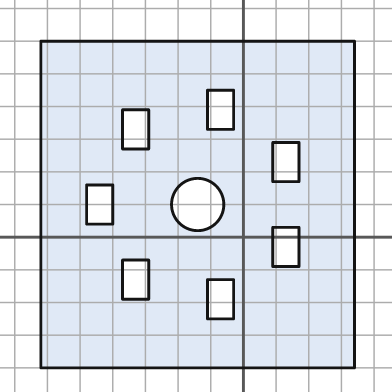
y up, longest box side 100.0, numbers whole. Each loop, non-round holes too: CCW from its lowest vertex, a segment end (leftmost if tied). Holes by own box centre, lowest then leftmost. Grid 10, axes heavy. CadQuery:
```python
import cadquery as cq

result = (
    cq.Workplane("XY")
    .moveTo(-62.0, -40.0)
    .lineTo(34.0, -40.0)
    .lineTo(34.0, 60.0)
    .lineTo(-62.0, 60.0)
    .close()
    .moveTo(-11.0, -25.0)
    .lineTo(-3.0, -25.0)
    .lineTo(-3.0, -13.0)
    .lineTo(-11.0, -13.0)
    .close()
    .moveTo(-37.0, -19.0)
    .lineTo(-29.0, -19.0)
    .lineTo(-29.0, -7.0)
    .lineTo(-37.0, -7.0)
    .close()
    .moveTo(9.0, -9.0)
    .lineTo(17.0, -9.0)
    .lineTo(17.0, 3.0)
    .lineTo(9.0, 3.0)
    .close()
    .moveTo(-48.0, 4.0)
    .lineTo(-40.0, 4.0)
    .lineTo(-40.0, 16.0)
    .lineTo(-48.0, 16.0)
    .close()
    .moveTo(-14.0, 10.0)
    .circle(8.0)
    .moveTo(9.0, 17.0)
    .lineTo(17.0, 17.0)
    .lineTo(17.0, 29.0)
    .lineTo(9.0, 29.0)
    .close()
    .moveTo(-37.0, 27.0)
    .lineTo(-29.0, 27.0)
    .lineTo(-29.0, 39.0)
    .lineTo(-37.0, 39.0)
    .close()
    .moveTo(-11.0, 33.0)
    .lineTo(-3.0, 33.0)
    .lineTo(-3.0, 45.0)
    .lineTo(-11.0, 45.0)
    .close()
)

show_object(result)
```